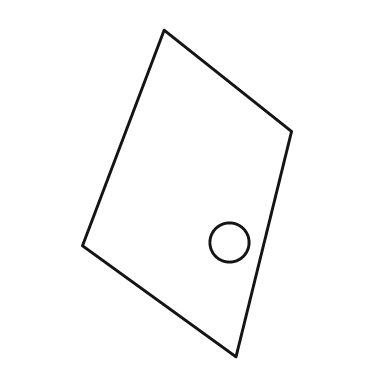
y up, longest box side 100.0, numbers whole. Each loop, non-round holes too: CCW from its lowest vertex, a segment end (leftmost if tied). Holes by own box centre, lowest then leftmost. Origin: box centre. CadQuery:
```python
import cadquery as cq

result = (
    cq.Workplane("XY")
    .moveTo(15.0, -50.0)
    .lineTo(32.0, 19.0)
    .lineTo(-7.0, 50.0)
    .lineTo(-32.0, -16.0)
    .close()
    .moveTo(13.0, -15.0)
    .circle(6.0)
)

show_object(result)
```